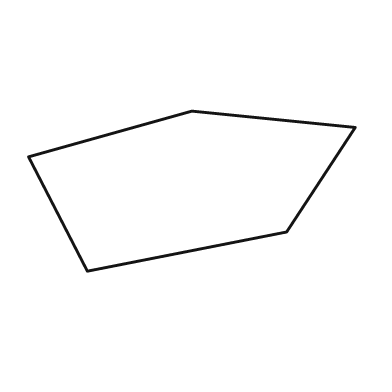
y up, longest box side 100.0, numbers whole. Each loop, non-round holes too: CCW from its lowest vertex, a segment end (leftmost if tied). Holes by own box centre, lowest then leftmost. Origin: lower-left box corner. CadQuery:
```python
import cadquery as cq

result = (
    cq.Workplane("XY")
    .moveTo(18.0, 0.0)
    .lineTo(79.0, 12.0)
    .lineTo(100.0, 44.0)
    .lineTo(50.0, 49.0)
    .lineTo(0.0, 35.0)
    .close()
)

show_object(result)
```